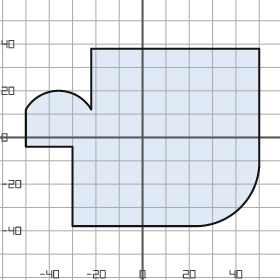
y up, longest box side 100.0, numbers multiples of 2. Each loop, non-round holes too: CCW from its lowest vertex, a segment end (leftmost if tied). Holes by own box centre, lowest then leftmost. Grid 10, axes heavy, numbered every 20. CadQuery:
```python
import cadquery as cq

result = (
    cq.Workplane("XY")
    .moveTo(-30.0, -38.0)
    .lineTo(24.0, -38.0)
    .threePointArc((42.0, -30.0), (50.0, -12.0))
    .lineTo(50.0, 38.0)
    .lineTo(-22.0, 38.0)
    .lineTo(-22.0, 12.0)
    .threePointArc((-36.0, 20.0), (-50.0, 12.0))
    .lineTo(-50.0, -4.0)
    .lineTo(-30.0, -4.0)
    .close()
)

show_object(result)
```